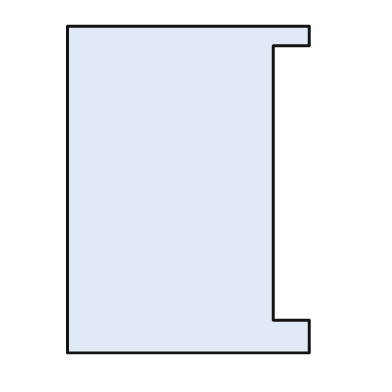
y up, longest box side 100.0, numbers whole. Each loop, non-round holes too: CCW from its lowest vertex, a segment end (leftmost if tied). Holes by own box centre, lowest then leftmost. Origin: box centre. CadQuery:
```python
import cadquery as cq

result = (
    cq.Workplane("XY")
    .moveTo(-37.0, -50.0)
    .lineTo(37.0, -50.0)
    .lineTo(37.0, -40.0)
    .lineTo(26.0, -40.0)
    .lineTo(26.0, 44.0)
    .lineTo(37.0, 44.0)
    .lineTo(37.0, 50.0)
    .lineTo(-37.0, 50.0)
    .close()
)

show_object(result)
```